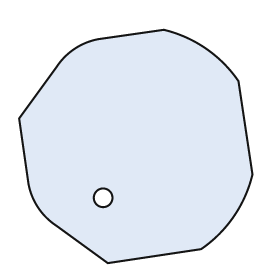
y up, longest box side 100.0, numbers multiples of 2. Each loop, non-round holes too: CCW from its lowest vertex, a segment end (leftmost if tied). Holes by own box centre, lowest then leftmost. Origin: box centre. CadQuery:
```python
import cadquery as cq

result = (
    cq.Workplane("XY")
    .moveTo(-12.0, -50.0)
    .lineTo(28.0, -44.0)
    .threePointArc((42.0, -30.0), (50.0, -12.0))
    .lineTo(44.0, 28.0)
    .threePointArc((30.0, 42.0), (12.0, 50.0))
    .lineTo(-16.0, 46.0)
    .threePointArc((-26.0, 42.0), (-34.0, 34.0))
    .lineTo(-50.0, 12.0)
    .lineTo(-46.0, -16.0)
    .threePointArc((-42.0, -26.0), (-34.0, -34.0))
    .close()
    .moveTo(-14.0, -22.0)
    .circle(4.0)
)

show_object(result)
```